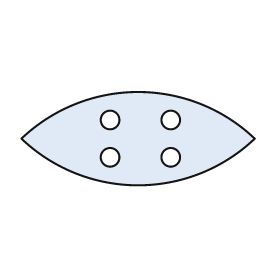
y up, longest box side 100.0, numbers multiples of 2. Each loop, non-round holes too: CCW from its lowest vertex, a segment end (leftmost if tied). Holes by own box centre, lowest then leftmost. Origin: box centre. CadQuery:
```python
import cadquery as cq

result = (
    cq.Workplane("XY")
    .moveTo(-50.0, 0.0)
    .threePointArc((0.0, -20.0), (50.0, 0.0))
    .threePointArc((0.0, 20.0), (-50.0, 0.0))
    .close()
    .moveTo(-12.0, -8.0)
    .circle(4.0)
    .moveTo(14.0, -8.0)
    .circle(4.0)
    .moveTo(-12.0, 8.0)
    .circle(4.0)
    .moveTo(14.0, 8.0)
    .circle(4.0)
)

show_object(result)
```